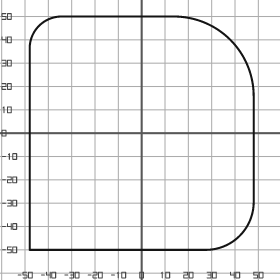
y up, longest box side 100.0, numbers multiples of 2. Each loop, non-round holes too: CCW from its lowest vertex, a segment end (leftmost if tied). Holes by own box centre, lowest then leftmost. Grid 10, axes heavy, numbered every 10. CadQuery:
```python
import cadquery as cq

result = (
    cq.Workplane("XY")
    .moveTo(-48.0, -50.0)
    .lineTo(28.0, -50.0)
    .threePointArc((42.0, -44.0), (48.0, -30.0))
    .lineTo(48.0, 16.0)
    .threePointArc((38.0, 40.0), (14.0, 50.0))
    .lineTo(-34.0, 50.0)
    .threePointArc((-44.0, 46.0), (-48.0, 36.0))
    .close()
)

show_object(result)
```